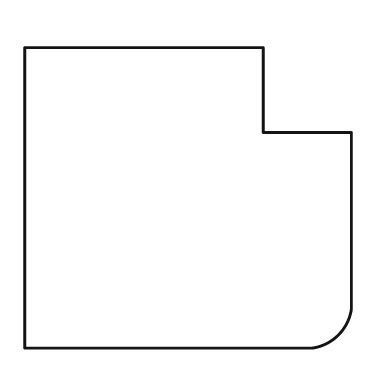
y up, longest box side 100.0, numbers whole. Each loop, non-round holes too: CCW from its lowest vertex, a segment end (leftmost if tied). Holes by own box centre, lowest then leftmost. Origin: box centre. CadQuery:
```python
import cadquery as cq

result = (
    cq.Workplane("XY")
    .moveTo(-50.0, -46.0)
    .lineTo(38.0, -46.0)
    .threePointArc((46.0, -42.0), (50.0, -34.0))
    .lineTo(50.0, 20.0)
    .lineTo(23.0, 20.0)
    .lineTo(23.0, 46.0)
    .lineTo(-50.0, 46.0)
    .close()
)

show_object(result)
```